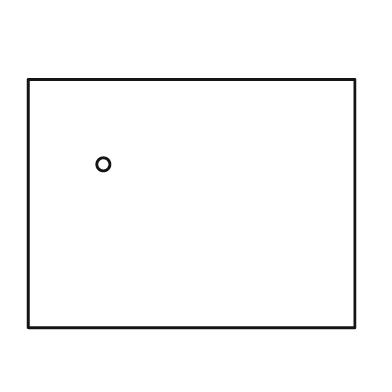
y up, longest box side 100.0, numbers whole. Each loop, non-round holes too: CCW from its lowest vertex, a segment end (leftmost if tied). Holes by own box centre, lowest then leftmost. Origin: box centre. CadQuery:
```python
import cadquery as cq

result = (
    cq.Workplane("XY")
    .moveTo(-50.0, -38.0)
    .lineTo(50.0, -38.0)
    .lineTo(50.0, 38.0)
    .lineTo(-50.0, 38.0)
    .close()
    .moveTo(-27.0, 12.0)
    .circle(2.0)
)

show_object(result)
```